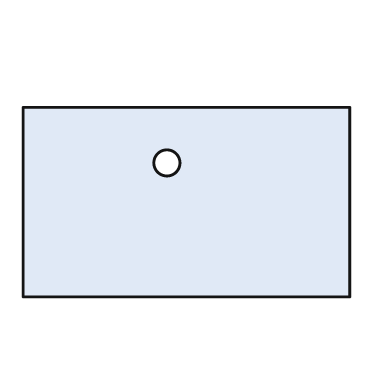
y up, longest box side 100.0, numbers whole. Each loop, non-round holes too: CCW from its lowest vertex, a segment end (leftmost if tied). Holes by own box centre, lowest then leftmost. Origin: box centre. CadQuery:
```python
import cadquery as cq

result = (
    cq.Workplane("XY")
    .moveTo(-50.0, -29.0)
    .lineTo(50.0, -29.0)
    .lineTo(50.0, 29.0)
    .lineTo(-50.0, 29.0)
    .close()
    .moveTo(-6.0, 12.0)
    .circle(4.0)
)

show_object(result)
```